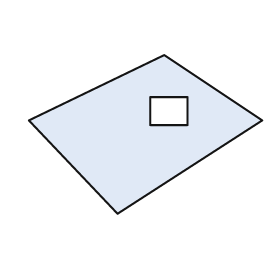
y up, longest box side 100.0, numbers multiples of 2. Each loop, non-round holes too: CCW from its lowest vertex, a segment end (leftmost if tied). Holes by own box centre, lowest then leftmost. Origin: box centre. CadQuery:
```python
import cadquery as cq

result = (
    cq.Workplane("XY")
    .moveTo(-12.0, -34.0)
    .lineTo(50.0, 6.0)
    .lineTo(8.0, 34.0)
    .lineTo(-50.0, 6.0)
    .close()
    .moveTo(2.0, 4.0)
    .lineTo(18.0, 4.0)
    .lineTo(18.0, 16.0)
    .lineTo(2.0, 16.0)
    .close()
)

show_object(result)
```